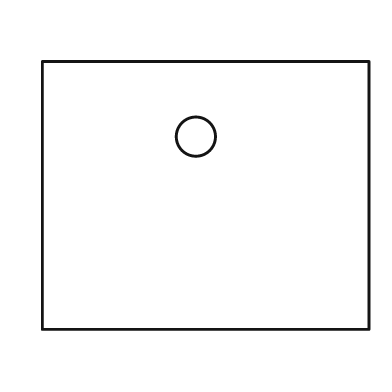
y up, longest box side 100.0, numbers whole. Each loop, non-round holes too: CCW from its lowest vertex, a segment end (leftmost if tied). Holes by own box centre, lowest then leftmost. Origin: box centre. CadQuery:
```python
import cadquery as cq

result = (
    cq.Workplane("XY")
    .moveTo(-50.0, -41.0)
    .lineTo(50.0, -41.0)
    .lineTo(50.0, 41.0)
    .lineTo(-50.0, 41.0)
    .close()
    .moveTo(-3.0, 18.0)
    .circle(6.0)
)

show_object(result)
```